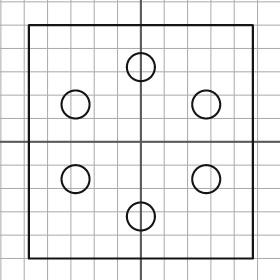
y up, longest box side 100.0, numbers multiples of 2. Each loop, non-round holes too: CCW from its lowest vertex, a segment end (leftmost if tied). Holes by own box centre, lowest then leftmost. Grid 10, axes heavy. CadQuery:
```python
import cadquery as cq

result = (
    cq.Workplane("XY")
    .moveTo(-48.0, -50.0)
    .lineTo(48.0, -50.0)
    .lineTo(48.0, 50.0)
    .lineTo(-48.0, 50.0)
    .close()
    .moveTo(0.0, -32.0)
    .circle(6.0)
    .moveTo(-28.0, -16.0)
    .circle(6.0)
    .moveTo(28.0, -16.0)
    .circle(6.0)
    .moveTo(-28.0, 16.0)
    .circle(6.0)
    .moveTo(28.0, 16.0)
    .circle(6.0)
    .moveTo(0.0, 32.0)
    .circle(6.0)
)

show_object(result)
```